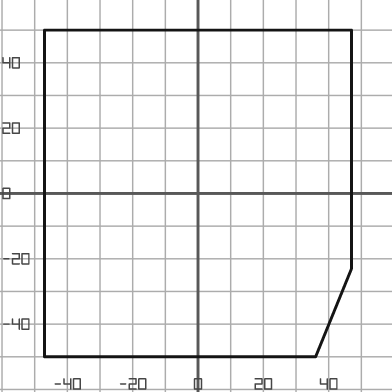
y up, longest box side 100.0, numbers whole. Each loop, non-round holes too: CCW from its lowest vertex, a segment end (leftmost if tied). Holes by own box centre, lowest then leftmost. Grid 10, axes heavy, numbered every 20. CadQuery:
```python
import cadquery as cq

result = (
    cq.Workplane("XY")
    .moveTo(-47.0, -50.0)
    .lineTo(36.0, -50.0)
    .lineTo(47.0, -23.0)
    .lineTo(47.0, 50.0)
    .lineTo(-47.0, 50.0)
    .close()
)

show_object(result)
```